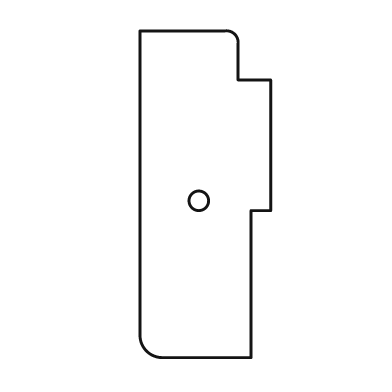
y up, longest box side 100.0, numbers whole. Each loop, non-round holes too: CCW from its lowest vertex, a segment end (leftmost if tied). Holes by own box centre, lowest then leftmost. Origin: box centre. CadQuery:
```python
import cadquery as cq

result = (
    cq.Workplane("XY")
    .moveTo(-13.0, -50.0)
    .lineTo(14.0, -50.0)
    .lineTo(14.0, -5.0)
    .lineTo(20.0, -5.0)
    .lineTo(20.0, 35.0)
    .lineTo(10.0, 35.0)
    .lineTo(10.0, 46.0)
    .threePointArc((9.0, 49.0), (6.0, 50.0))
    .lineTo(-20.0, 50.0)
    .lineTo(-20.0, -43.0)
    .threePointArc((-18.0, -48.0), (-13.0, -50.0))
    .close()
    .moveTo(-2.0, -2.0)
    .circle(3.0)
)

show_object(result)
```